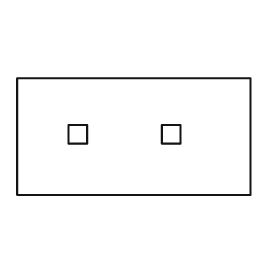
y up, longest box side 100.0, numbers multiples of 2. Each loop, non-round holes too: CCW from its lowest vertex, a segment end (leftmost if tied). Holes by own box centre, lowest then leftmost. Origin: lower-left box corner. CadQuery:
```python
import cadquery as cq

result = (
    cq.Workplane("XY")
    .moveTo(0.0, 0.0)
    .lineTo(100.0, 0.0)
    .lineTo(100.0, 50.0)
    .lineTo(0.0, 50.0)
    .close()
    .moveTo(22.0, 22.0)
    .lineTo(30.0, 22.0)
    .lineTo(30.0, 30.0)
    .lineTo(22.0, 30.0)
    .close()
    .moveTo(62.0, 22.0)
    .lineTo(70.0, 22.0)
    .lineTo(70.0, 30.0)
    .lineTo(62.0, 30.0)
    .close()
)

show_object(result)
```